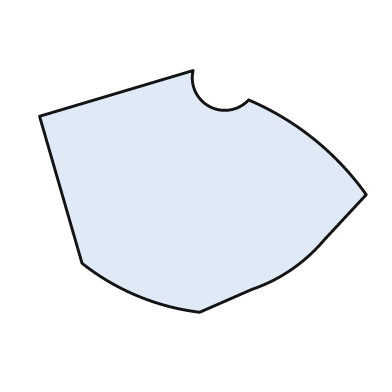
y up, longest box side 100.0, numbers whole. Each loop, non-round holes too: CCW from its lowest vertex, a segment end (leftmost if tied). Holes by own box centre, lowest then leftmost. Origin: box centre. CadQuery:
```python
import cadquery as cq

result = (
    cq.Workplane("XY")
    .moveTo(-1.0, -37.0)
    .lineTo(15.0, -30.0)
    .threePointArc((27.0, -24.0), (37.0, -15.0))
    .lineTo(50.0, -1.0)
    .threePointArc((34.0, 16.0), (14.0, 28.0))
    .threePointArc((2.0, 26.0), (-3.0, 37.0))
    .lineTo(-50.0, 23.0)
    .lineTo(-37.0, -22.0)
    .threePointArc((-20.0, -32.0), (-1.0, -37.0))
    .close()
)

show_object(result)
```